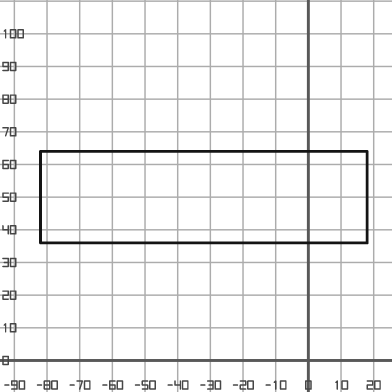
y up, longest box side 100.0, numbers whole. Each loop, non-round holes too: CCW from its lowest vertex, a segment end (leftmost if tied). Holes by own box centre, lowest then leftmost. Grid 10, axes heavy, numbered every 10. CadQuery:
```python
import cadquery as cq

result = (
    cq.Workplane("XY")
    .moveTo(-82.0, 36.0)
    .lineTo(18.0, 36.0)
    .lineTo(18.0, 64.0)
    .lineTo(-82.0, 64.0)
    .close()
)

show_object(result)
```